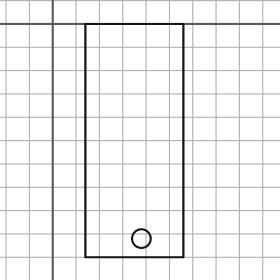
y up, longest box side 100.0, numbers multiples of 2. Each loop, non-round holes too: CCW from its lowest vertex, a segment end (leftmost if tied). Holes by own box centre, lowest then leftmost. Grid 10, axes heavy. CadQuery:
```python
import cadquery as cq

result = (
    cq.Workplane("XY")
    .moveTo(14.0, -100.0)
    .lineTo(56.0, -100.0)
    .lineTo(56.0, 0.0)
    .lineTo(14.0, 0.0)
    .close()
    .moveTo(38.0, -92.0)
    .circle(4.0)
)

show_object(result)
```